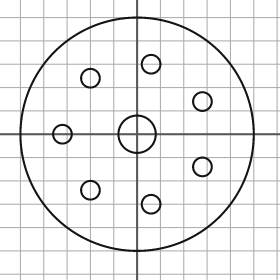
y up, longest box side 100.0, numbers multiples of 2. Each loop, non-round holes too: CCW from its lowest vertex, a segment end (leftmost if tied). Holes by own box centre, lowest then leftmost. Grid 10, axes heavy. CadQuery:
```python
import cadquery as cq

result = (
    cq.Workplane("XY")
    .moveTo(0.0, 0.0)
    .circle(50.0)
    .moveTo(6.0, -30.0)
    .circle(4.0)
    .moveTo(-20.0, -24.0)
    .circle(4.0)
    .moveTo(28.0, -14.0)
    .circle(4.0)
    .moveTo(-32.0, 0.0)
    .circle(4.0)
    .moveTo(0.0, 0.0)
    .circle(8.0)
    .moveTo(28.0, 14.0)
    .circle(4.0)
    .moveTo(-20.0, 24.0)
    .circle(4.0)
    .moveTo(6.0, 30.0)
    .circle(4.0)
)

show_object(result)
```